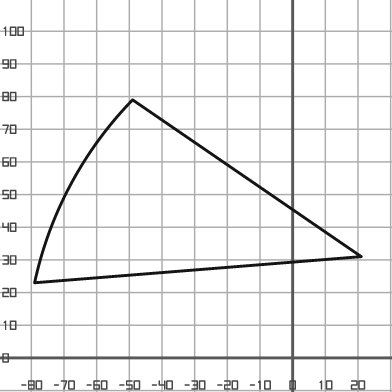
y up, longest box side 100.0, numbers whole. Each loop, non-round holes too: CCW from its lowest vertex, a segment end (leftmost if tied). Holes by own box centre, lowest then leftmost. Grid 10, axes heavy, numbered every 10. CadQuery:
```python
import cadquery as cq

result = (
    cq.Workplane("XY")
    .moveTo(-79.0, 23.0)
    .lineTo(21.0, 31.0)
    .lineTo(-49.0, 79.0)
    .threePointArc((-68.0, 53.0), (-79.0, 23.0))
    .close()
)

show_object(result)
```